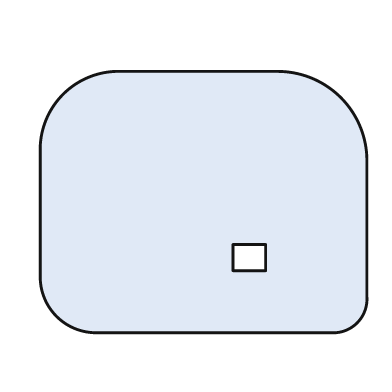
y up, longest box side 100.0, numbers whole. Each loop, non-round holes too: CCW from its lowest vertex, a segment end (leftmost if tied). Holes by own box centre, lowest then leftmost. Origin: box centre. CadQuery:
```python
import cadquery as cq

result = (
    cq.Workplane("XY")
    .moveTo(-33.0, -40.0)
    .lineTo(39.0, -40.0)
    .threePointArc((47.0, -37.0), (50.0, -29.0))
    .lineTo(50.0, 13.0)
    .threePointArc((42.0, 32.0), (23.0, 40.0))
    .lineTo(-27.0, 40.0)
    .threePointArc((-43.0, 33.0), (-50.0, 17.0))
    .lineTo(-50.0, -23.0)
    .threePointArc((-45.0, -35.0), (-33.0, -40.0))
    .close()
    .moveTo(9.0, -21.0)
    .lineTo(19.0, -21.0)
    .lineTo(19.0, -13.0)
    .lineTo(9.0, -13.0)
    .close()
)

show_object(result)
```